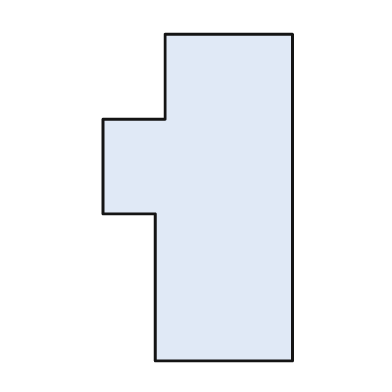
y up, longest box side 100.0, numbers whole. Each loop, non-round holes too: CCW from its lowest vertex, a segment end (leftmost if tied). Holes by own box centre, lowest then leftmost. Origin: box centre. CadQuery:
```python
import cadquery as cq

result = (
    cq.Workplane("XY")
    .moveTo(-13.0, -50.0)
    .lineTo(29.0, -50.0)
    .lineTo(29.0, 50.0)
    .lineTo(-10.0, 50.0)
    .lineTo(-10.0, 24.0)
    .lineTo(-29.0, 24.0)
    .lineTo(-29.0, -5.0)
    .lineTo(-13.0, -5.0)
    .close()
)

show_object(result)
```